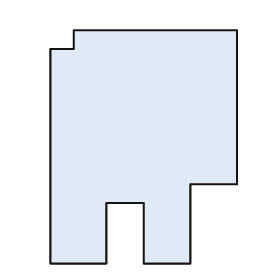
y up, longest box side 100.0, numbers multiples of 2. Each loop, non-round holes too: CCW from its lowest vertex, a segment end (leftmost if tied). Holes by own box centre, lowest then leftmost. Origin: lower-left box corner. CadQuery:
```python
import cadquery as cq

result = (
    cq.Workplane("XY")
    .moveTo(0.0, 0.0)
    .lineTo(24.0, 0.0)
    .lineTo(24.0, 26.0)
    .lineTo(40.0, 26.0)
    .lineTo(40.0, 0.0)
    .lineTo(60.0, 0.0)
    .lineTo(60.0, 34.0)
    .lineTo(80.0, 34.0)
    .lineTo(80.0, 100.0)
    .lineTo(10.0, 100.0)
    .lineTo(10.0, 92.0)
    .lineTo(0.0, 92.0)
    .close()
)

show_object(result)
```